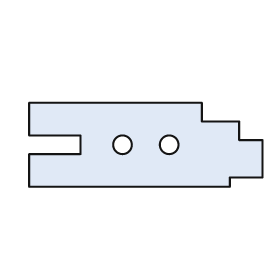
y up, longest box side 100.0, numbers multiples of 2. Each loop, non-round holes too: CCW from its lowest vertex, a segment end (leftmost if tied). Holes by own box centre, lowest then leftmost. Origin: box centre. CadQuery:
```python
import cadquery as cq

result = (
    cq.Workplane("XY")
    .moveTo(-50.0, -18.0)
    .lineTo(36.0, -18.0)
    .lineTo(36.0, -14.0)
    .lineTo(50.0, -14.0)
    .lineTo(50.0, 2.0)
    .lineTo(40.0, 2.0)
    .lineTo(40.0, 10.0)
    .lineTo(24.0, 10.0)
    .lineTo(24.0, 18.0)
    .lineTo(-50.0, 18.0)
    .lineTo(-50.0, 4.0)
    .lineTo(-28.0, 4.0)
    .lineTo(-28.0, -4.0)
    .lineTo(-50.0, -4.0)
    .close()
    .moveTo(-10.0, 0.0)
    .circle(4.0)
    .moveTo(10.0, 0.0)
    .circle(4.0)
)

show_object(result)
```